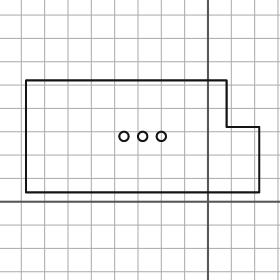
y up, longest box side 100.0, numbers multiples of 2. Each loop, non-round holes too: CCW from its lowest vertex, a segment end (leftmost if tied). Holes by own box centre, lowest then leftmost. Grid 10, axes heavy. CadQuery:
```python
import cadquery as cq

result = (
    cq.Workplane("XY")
    .moveTo(-78.0, 4.0)
    .lineTo(22.0, 4.0)
    .lineTo(22.0, 32.0)
    .lineTo(8.0, 32.0)
    .lineTo(8.0, 52.0)
    .lineTo(-78.0, 52.0)
    .close()
    .moveTo(-36.0, 28.0)
    .circle(2.0)
    .moveTo(-28.0, 28.0)
    .circle(2.0)
    .moveTo(-20.0, 28.0)
    .circle(2.0)
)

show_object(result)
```